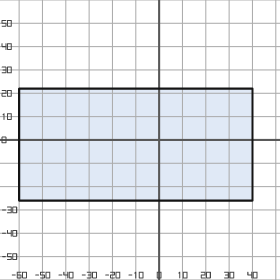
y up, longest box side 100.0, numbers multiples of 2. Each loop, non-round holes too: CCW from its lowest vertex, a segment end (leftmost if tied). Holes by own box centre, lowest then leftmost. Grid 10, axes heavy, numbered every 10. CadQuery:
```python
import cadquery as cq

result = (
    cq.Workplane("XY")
    .moveTo(-60.0, -26.0)
    .lineTo(40.0, -26.0)
    .lineTo(40.0, 22.0)
    .lineTo(-60.0, 22.0)
    .close()
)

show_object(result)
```